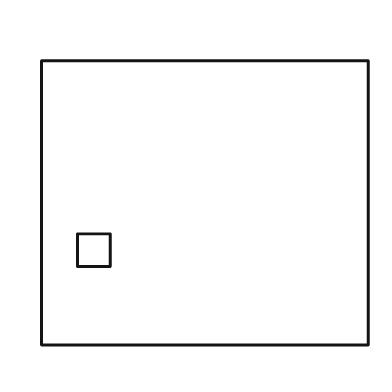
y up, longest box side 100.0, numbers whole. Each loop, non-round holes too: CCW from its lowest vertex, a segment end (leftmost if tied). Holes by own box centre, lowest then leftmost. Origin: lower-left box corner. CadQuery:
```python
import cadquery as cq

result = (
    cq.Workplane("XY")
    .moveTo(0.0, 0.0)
    .lineTo(100.0, 0.0)
    .lineTo(100.0, 87.0)
    .lineTo(0.0, 87.0)
    .close()
    .moveTo(11.0, 24.0)
    .lineTo(21.0, 24.0)
    .lineTo(21.0, 34.0)
    .lineTo(11.0, 34.0)
    .close()
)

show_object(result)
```